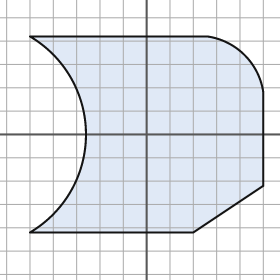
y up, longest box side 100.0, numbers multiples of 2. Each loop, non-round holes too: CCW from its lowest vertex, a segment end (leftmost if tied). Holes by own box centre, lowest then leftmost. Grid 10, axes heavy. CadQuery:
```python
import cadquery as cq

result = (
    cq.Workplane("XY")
    .moveTo(-50.0, -42.0)
    .lineTo(20.0, -42.0)
    .lineTo(50.0, -22.0)
    .lineTo(50.0, 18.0)
    .threePointArc((42.0, 34.0), (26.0, 42.0))
    .lineTo(-50.0, 42.0)
    .threePointArc((-26.0, 0.0), (-50.0, -42.0))
    .close()
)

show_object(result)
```